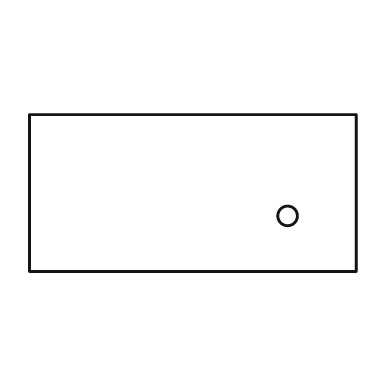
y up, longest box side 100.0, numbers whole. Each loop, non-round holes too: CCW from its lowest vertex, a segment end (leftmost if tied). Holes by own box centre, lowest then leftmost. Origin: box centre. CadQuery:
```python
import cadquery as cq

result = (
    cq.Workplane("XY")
    .moveTo(-50.0, -24.0)
    .lineTo(50.0, -24.0)
    .lineTo(50.0, 24.0)
    .lineTo(-50.0, 24.0)
    .close()
    .moveTo(29.0, -7.0)
    .circle(3.0)
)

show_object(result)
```